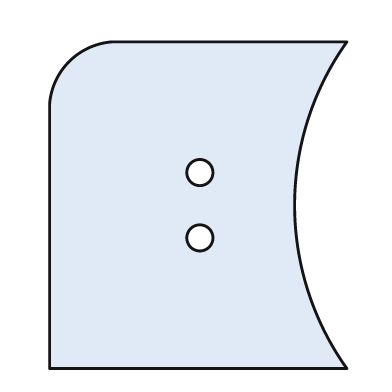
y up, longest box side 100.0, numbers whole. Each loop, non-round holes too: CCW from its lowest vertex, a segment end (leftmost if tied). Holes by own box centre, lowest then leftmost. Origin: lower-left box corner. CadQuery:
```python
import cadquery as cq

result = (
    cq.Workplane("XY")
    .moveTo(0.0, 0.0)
    .lineTo(91.0, 0.0)
    .threePointArc((75.0, 50.0), (91.0, 100.0))
    .lineTo(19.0, 100.0)
    .threePointArc((6.0, 94.0), (0.0, 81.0))
    .close()
    .moveTo(46.0, 40.0)
    .circle(4.0)
    .moveTo(46.0, 60.0)
    .circle(4.0)
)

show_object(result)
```